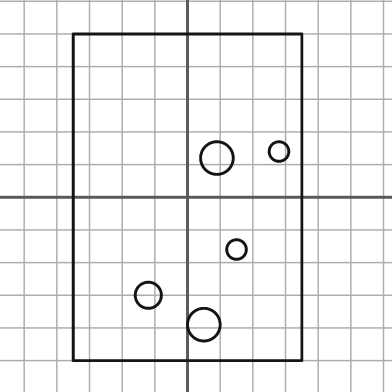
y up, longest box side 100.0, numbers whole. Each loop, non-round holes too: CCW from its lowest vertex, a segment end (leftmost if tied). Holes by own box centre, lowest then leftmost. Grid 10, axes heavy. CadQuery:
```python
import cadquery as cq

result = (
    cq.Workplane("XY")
    .moveTo(-35.0, -50.0)
    .lineTo(35.0, -50.0)
    .lineTo(35.0, 50.0)
    .lineTo(-35.0, 50.0)
    .close()
    .moveTo(5.0, -39.0)
    .circle(5.0)
    .moveTo(-12.0, -30.0)
    .circle(4.0)
    .moveTo(15.0, -16.0)
    .circle(3.0)
    .moveTo(9.0, 12.0)
    .circle(5.0)
    .moveTo(28.0, 14.0)
    .circle(3.0)
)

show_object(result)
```